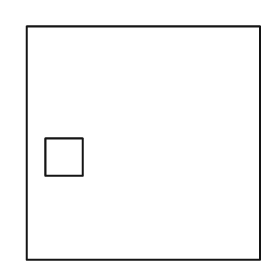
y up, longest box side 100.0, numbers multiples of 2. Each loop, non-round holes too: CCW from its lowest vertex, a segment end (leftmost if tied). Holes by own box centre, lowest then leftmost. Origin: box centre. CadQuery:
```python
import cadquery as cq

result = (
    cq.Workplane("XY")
    .moveTo(-50.0, -50.0)
    .lineTo(50.0, -50.0)
    .lineTo(50.0, 50.0)
    .lineTo(-50.0, 50.0)
    .close()
    .moveTo(-42.0, -14.0)
    .lineTo(-26.0, -14.0)
    .lineTo(-26.0, 2.0)
    .lineTo(-42.0, 2.0)
    .close()
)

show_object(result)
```